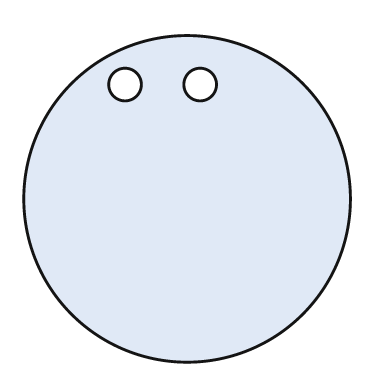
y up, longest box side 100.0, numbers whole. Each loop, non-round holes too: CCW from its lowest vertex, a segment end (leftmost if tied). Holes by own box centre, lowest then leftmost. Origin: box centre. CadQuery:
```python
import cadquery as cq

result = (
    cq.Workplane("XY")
    .moveTo(0.0, 0.0)
    .circle(50.0)
    .moveTo(-19.0, 35.0)
    .circle(5.0)
    .moveTo(4.0, 35.0)
    .circle(5.0)
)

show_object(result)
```